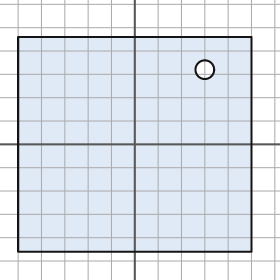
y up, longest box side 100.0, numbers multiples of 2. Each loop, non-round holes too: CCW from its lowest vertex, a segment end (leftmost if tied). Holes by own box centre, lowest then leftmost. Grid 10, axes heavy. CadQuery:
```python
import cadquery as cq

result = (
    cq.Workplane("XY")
    .moveTo(-50.0, -46.0)
    .lineTo(50.0, -46.0)
    .lineTo(50.0, 46.0)
    .lineTo(-50.0, 46.0)
    .close()
    .moveTo(30.0, 32.0)
    .circle(4.0)
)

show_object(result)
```